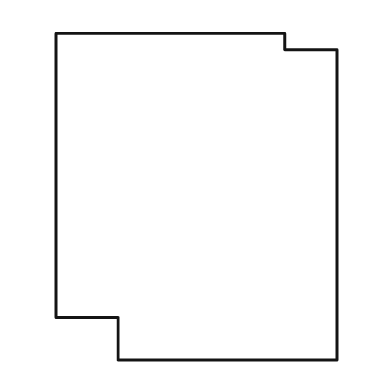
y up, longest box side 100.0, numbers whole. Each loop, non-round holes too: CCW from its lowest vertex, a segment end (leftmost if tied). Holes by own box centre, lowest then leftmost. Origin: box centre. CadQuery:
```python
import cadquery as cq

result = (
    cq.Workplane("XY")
    .moveTo(-24.0, -50.0)
    .lineTo(43.0, -50.0)
    .lineTo(43.0, 45.0)
    .lineTo(27.0, 45.0)
    .lineTo(27.0, 50.0)
    .lineTo(-43.0, 50.0)
    .lineTo(-43.0, -37.0)
    .lineTo(-24.0, -37.0)
    .close()
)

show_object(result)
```